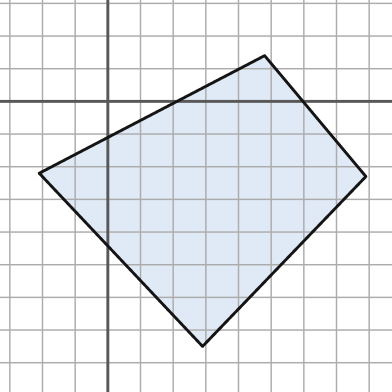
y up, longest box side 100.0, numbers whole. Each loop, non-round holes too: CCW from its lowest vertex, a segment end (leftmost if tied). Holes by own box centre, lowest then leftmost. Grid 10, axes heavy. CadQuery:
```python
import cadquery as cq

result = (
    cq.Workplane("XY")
    .moveTo(29.0, -75.0)
    .lineTo(79.0, -23.0)
    .lineTo(48.0, 14.0)
    .lineTo(-21.0, -22.0)
    .close()
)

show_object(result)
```